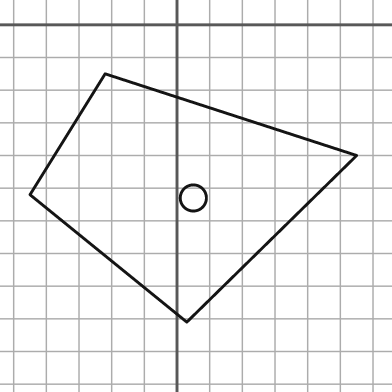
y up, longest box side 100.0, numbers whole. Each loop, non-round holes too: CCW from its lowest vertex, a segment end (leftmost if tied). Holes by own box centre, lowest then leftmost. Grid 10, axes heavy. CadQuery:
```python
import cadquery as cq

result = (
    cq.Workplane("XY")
    .moveTo(3.0, -91.0)
    .lineTo(55.0, -40.0)
    .lineTo(-22.0, -15.0)
    .lineTo(-45.0, -52.0)
    .close()
    .moveTo(5.0, -53.0)
    .circle(4.0)
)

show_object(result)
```